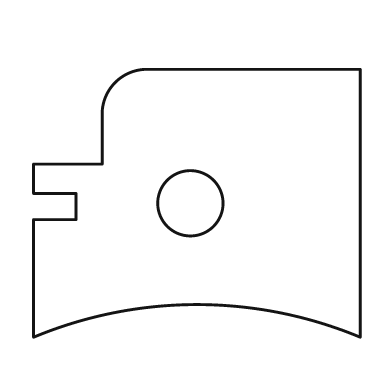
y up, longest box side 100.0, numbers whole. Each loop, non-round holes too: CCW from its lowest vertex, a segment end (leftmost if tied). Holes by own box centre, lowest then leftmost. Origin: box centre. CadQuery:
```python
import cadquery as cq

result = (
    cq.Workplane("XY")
    .moveTo(-50.0, -41.0)
    .threePointArc((0.0, -31.0), (50.0, -41.0))
    .lineTo(50.0, 41.0)
    .lineTo(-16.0, 41.0)
    .threePointArc((-25.0, 37.0), (-29.0, 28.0))
    .lineTo(-29.0, 12.0)
    .lineTo(-50.0, 12.0)
    .lineTo(-50.0, 3.0)
    .lineTo(-37.0, 3.0)
    .lineTo(-37.0, -5.0)
    .lineTo(-50.0, -5.0)
    .close()
    .moveTo(-2.0, 0.0)
    .circle(10.0)
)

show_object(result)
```